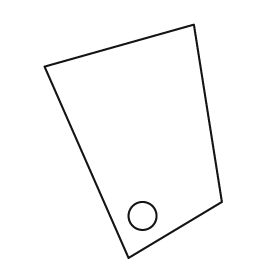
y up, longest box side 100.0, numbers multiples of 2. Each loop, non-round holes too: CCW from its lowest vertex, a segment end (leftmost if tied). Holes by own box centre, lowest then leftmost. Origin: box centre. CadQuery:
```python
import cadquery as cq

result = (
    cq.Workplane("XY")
    .moveTo(-2.0, -50.0)
    .lineTo(38.0, -26.0)
    .lineTo(26.0, 50.0)
    .lineTo(-38.0, 32.0)
    .close()
    .moveTo(4.0, -32.0)
    .circle(6.0)
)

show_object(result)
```